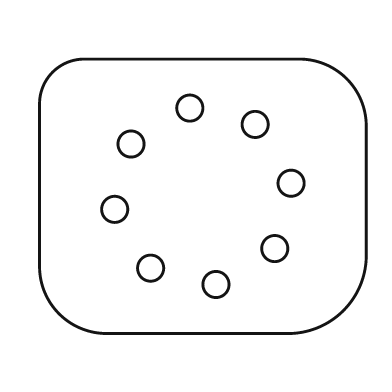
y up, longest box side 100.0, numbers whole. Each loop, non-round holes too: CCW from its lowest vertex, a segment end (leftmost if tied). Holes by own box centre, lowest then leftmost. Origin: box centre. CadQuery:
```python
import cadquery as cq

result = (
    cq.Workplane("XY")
    .moveTo(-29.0, -42.0)
    .lineTo(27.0, -42.0)
    .threePointArc((43.0, -35.0), (50.0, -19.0))
    .lineTo(50.0, 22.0)
    .threePointArc((44.0, 36.0), (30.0, 42.0))
    .lineTo(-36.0, 42.0)
    .threePointArc((-46.0, 38.0), (-50.0, 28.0))
    .lineTo(-50.0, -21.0)
    .threePointArc((-44.0, -36.0), (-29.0, -42.0))
    .close()
    .moveTo(4.0, -27.0)
    .circle(4.0)
    .moveTo(-16.0, -22.0)
    .circle(4.0)
    .moveTo(22.0, -16.0)
    .circle(4.0)
    .moveTo(-27.0, -4.0)
    .circle(4.0)
    .moveTo(27.0, 4.0)
    .circle(4.0)
    .moveTo(-22.0, 16.0)
    .circle(4.0)
    .moveTo(16.0, 22.0)
    .circle(4.0)
    .moveTo(-4.0, 27.0)
    .circle(4.0)
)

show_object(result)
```